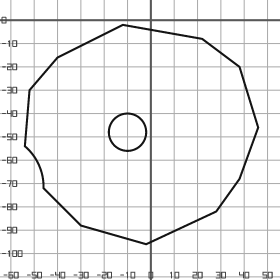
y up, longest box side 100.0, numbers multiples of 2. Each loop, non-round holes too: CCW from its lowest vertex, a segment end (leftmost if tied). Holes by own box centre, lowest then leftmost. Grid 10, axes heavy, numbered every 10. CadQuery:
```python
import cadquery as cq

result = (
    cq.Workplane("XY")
    .moveTo(-2.0, -96.0)
    .lineTo(28.0, -82.0)
    .lineTo(38.0, -68.0)
    .lineTo(46.0, -46.0)
    .lineTo(38.0, -20.0)
    .lineTo(22.0, -8.0)
    .lineTo(-12.0, -2.0)
    .lineTo(-40.0, -16.0)
    .lineTo(-52.0, -30.0)
    .lineTo(-54.0, -54.0)
    .threePointArc((-48.0, -62.0), (-46.0, -72.0))
    .lineTo(-30.0, -88.0)
    .close()
    .moveTo(-10.0, -48.0)
    .circle(8.0)
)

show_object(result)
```